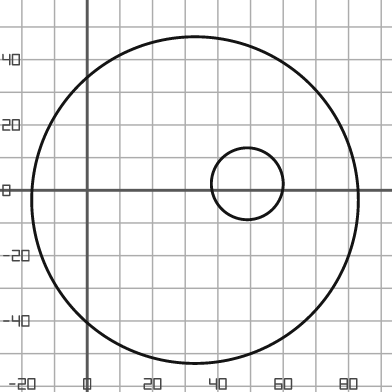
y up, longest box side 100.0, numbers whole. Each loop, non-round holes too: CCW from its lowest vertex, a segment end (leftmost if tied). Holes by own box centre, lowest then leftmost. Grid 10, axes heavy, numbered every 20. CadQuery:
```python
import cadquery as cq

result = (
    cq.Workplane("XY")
    .moveTo(33.0, -3.0)
    .circle(50.0)
    .moveTo(49.0, 2.0)
    .circle(11.0)
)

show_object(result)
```